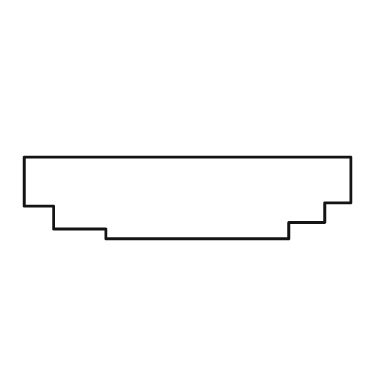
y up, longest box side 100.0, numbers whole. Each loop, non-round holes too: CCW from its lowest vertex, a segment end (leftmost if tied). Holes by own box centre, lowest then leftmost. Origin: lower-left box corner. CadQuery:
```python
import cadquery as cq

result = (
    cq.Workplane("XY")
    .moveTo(25.0, 0.0)
    .lineTo(81.0, 0.0)
    .lineTo(81.0, 5.0)
    .lineTo(92.0, 5.0)
    .lineTo(92.0, 11.0)
    .lineTo(100.0, 11.0)
    .lineTo(100.0, 25.0)
    .lineTo(0.0, 25.0)
    .lineTo(0.0, 10.0)
    .lineTo(9.0, 10.0)
    .lineTo(9.0, 3.0)
    .lineTo(25.0, 3.0)
    .close()
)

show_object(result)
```